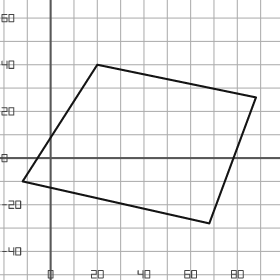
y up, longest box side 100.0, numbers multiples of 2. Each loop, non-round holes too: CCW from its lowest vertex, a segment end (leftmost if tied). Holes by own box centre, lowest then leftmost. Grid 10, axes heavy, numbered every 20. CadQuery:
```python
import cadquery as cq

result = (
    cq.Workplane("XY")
    .moveTo(68.0, -28.0)
    .lineTo(88.0, 26.0)
    .lineTo(20.0, 40.0)
    .lineTo(-12.0, -10.0)
    .close()
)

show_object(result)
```